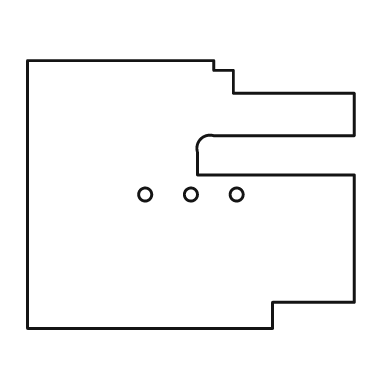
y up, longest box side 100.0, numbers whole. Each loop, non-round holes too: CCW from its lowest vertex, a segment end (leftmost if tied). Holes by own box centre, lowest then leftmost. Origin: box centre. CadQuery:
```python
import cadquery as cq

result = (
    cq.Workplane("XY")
    .moveTo(-50.0, -41.0)
    .lineTo(25.0, -41.0)
    .lineTo(25.0, -33.0)
    .lineTo(50.0, -33.0)
    .lineTo(50.0, 6.0)
    .lineTo(2.0, 6.0)
    .lineTo(2.0, 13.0)
    .threePointArc((3.0, 17.0), (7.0, 18.0))
    .lineTo(50.0, 18.0)
    .lineTo(50.0, 31.0)
    .lineTo(13.0, 31.0)
    .lineTo(13.0, 38.0)
    .lineTo(7.0, 38.0)
    .lineTo(7.0, 41.0)
    .lineTo(-50.0, 41.0)
    .close()
    .moveTo(-14.0, 0.0)
    .circle(2.0)
    .moveTo(0.0, 0.0)
    .circle(2.0)
    .moveTo(14.0, 0.0)
    .circle(2.0)
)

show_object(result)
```